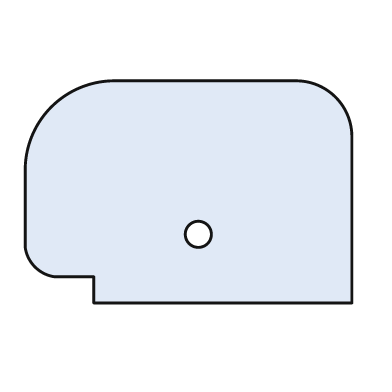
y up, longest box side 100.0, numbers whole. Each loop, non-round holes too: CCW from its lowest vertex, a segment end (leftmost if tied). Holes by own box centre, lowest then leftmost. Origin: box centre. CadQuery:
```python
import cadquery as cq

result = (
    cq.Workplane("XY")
    .moveTo(-29.0, -34.0)
    .lineTo(50.0, -34.0)
    .lineTo(50.0, 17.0)
    .threePointArc((45.0, 29.0), (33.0, 34.0))
    .lineTo(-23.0, 34.0)
    .threePointArc((-42.0, 26.0), (-50.0, 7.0))
    .lineTo(-50.0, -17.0)
    .threePointArc((-47.0, -23.0), (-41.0, -26.0))
    .lineTo(-29.0, -26.0)
    .close()
    .moveTo(3.0, -13.0)
    .circle(4.0)
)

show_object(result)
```